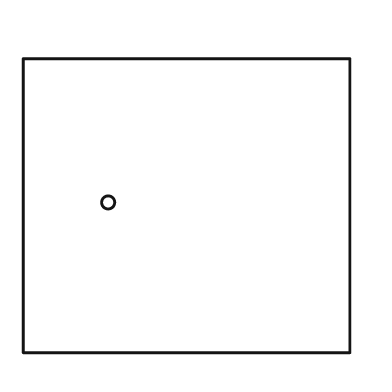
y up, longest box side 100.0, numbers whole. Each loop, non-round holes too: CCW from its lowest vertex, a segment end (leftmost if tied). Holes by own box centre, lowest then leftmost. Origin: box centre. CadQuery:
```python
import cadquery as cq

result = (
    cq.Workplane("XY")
    .moveTo(-50.0, -45.0)
    .lineTo(50.0, -45.0)
    .lineTo(50.0, 45.0)
    .lineTo(-50.0, 45.0)
    .close()
    .moveTo(-24.0, 1.0)
    .circle(2.0)
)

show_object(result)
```